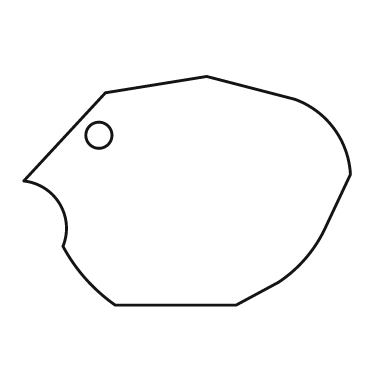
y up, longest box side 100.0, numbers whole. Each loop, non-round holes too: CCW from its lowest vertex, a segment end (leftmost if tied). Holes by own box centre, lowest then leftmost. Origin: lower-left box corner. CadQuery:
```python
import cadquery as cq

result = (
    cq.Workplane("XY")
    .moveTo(28.0, 0.0)
    .lineTo(65.0, 0.0)
    .lineTo(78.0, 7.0)
    .threePointArc((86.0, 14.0), (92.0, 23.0))
    .lineTo(100.0, 40.0)
    .threePointArc((95.0, 54.0), (83.0, 63.0))
    .lineTo(56.0, 70.0)
    .lineTo(25.0, 65.0)
    .lineTo(0.0, 38.0)
    .threePointArc((11.0, 31.0), (12.0, 18.0))
    .threePointArc((19.0, 8.0), (28.0, 0.0))
    .close()
    .moveTo(23.0, 52.0)
    .circle(4.0)
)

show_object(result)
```